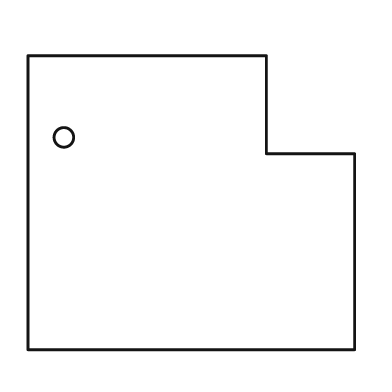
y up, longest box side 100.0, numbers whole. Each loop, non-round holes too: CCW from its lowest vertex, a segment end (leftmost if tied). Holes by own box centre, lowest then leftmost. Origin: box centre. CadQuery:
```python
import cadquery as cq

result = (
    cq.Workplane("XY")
    .moveTo(-50.0, -45.0)
    .lineTo(50.0, -45.0)
    .lineTo(50.0, 15.0)
    .lineTo(23.0, 15.0)
    .lineTo(23.0, 45.0)
    .lineTo(-50.0, 45.0)
    .close()
    .moveTo(-39.0, 20.0)
    .circle(3.0)
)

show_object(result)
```